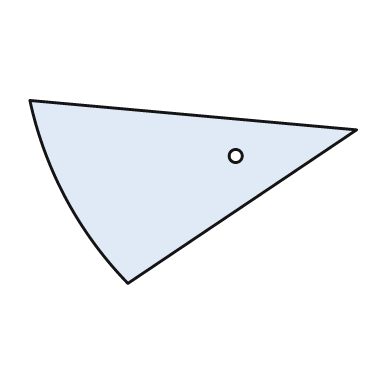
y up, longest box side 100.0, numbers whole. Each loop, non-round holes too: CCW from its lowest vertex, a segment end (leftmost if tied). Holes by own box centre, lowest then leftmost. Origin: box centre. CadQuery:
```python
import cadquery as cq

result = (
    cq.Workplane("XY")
    .moveTo(-20.0, -28.0)
    .lineTo(50.0, 19.0)
    .lineTo(-50.0, 28.0)
    .threePointArc((-39.0, -2.0), (-20.0, -28.0))
    .close()
    .moveTo(13.0, 11.0)
    .circle(2.0)
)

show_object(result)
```